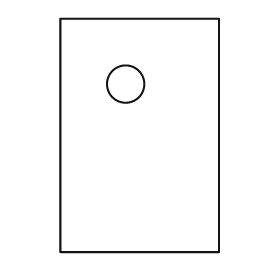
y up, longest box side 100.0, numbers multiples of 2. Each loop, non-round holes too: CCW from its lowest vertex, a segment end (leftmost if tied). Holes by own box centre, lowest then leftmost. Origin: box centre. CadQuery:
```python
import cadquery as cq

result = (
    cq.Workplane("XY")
    .moveTo(-34.0, -50.0)
    .lineTo(34.0, -50.0)
    .lineTo(34.0, 50.0)
    .lineTo(-34.0, 50.0)
    .close()
    .moveTo(-6.0, 22.0)
    .circle(8.0)
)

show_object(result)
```